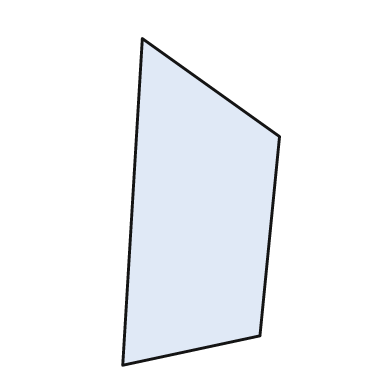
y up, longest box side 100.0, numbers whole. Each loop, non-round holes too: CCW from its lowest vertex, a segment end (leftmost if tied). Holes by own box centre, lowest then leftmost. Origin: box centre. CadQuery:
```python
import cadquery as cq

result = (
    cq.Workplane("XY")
    .moveTo(-24.0, -50.0)
    .lineTo(18.0, -41.0)
    .lineTo(24.0, 20.0)
    .lineTo(-18.0, 50.0)
    .close()
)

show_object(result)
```